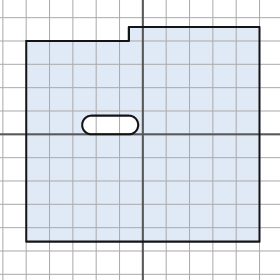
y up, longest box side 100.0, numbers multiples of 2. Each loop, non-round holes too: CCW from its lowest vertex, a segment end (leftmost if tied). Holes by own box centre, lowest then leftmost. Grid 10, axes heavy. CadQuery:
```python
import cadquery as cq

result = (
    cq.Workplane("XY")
    .moveTo(-50.0, -46.0)
    .lineTo(50.0, -46.0)
    .lineTo(50.0, 46.0)
    .lineTo(-6.0, 46.0)
    .lineTo(-6.0, 40.0)
    .lineTo(-50.0, 40.0)
    .close()
    .moveTo(-22.0, 0.0)
    .lineTo(-6.0, 0.0)
    .threePointArc((-2.0, 4.0), (-6.0, 8.0))
    .lineTo(-22.0, 8.0)
    .threePointArc((-26.0, 4.0), (-22.0, 0.0))
    .close()
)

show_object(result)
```